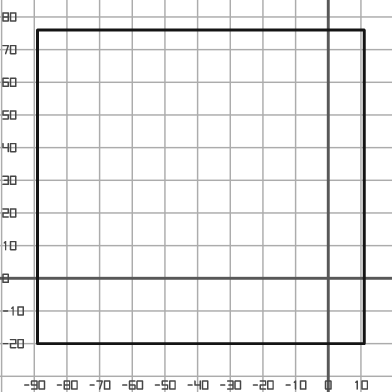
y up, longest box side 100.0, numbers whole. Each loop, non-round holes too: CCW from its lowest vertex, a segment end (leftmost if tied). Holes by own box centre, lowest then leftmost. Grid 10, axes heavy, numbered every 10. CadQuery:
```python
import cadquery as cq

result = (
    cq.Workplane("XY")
    .moveTo(-89.0, -20.0)
    .lineTo(11.0, -20.0)
    .lineTo(11.0, 76.0)
    .lineTo(-89.0, 76.0)
    .close()
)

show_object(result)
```